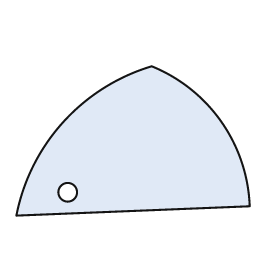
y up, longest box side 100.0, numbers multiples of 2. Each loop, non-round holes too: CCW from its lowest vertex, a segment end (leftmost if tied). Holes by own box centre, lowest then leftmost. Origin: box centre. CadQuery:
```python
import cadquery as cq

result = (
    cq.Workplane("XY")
    .moveTo(-50.0, -32.0)
    .lineTo(50.0, -28.0)
    .threePointArc((38.0, 8.0), (8.0, 32.0))
    .threePointArc((-30.0, 8.0), (-50.0, -32.0))
    .close()
    .moveTo(-28.0, -22.0)
    .circle(4.0)
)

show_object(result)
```